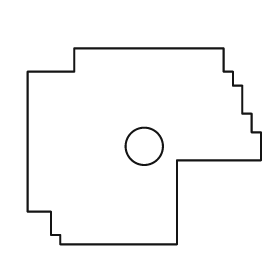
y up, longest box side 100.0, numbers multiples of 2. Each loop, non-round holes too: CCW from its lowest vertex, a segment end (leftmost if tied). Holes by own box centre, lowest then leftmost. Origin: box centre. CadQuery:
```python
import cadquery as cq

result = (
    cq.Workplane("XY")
    .moveTo(-36.0, -42.0)
    .lineTo(14.0, -42.0)
    .lineTo(14.0, -6.0)
    .lineTo(50.0, -6.0)
    .lineTo(50.0, 6.0)
    .lineTo(46.0, 6.0)
    .lineTo(46.0, 14.0)
    .lineTo(42.0, 14.0)
    .lineTo(42.0, 26.0)
    .lineTo(38.0, 26.0)
    .lineTo(38.0, 32.0)
    .lineTo(34.0, 32.0)
    .lineTo(34.0, 42.0)
    .lineTo(-30.0, 42.0)
    .lineTo(-30.0, 32.0)
    .lineTo(-50.0, 32.0)
    .lineTo(-50.0, -28.0)
    .lineTo(-40.0, -28.0)
    .lineTo(-40.0, -38.0)
    .lineTo(-36.0, -38.0)
    .close()
    .moveTo(0.0, 0.0)
    .circle(8.0)
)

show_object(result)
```